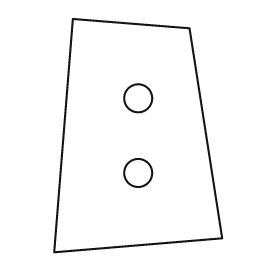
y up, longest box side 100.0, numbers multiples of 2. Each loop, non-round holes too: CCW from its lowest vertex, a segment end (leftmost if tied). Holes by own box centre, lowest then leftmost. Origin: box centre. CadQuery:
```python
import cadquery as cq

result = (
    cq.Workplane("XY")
    .moveTo(-36.0, -50.0)
    .lineTo(36.0, -44.0)
    .lineTo(22.0, 46.0)
    .lineTo(-28.0, 50.0)
    .close()
    .moveTo(0.0, -16.0)
    .circle(6.0)
    .moveTo(0.0, 16.0)
    .circle(6.0)
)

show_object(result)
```